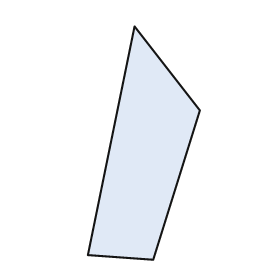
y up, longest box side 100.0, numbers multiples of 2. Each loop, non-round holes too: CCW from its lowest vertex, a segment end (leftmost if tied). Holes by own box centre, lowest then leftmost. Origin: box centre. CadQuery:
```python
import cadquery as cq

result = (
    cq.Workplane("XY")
    .moveTo(4.0, -50.0)
    .lineTo(24.0, 14.0)
    .lineTo(-4.0, 50.0)
    .lineTo(-24.0, -48.0)
    .close()
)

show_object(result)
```